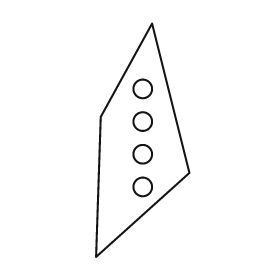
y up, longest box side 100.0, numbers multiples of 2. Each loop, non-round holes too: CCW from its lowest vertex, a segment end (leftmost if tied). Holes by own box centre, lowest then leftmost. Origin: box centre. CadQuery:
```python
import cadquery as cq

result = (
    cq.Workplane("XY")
    .moveTo(-20.0, -50.0)
    .lineTo(20.0, -14.0)
    .lineTo(4.0, 50.0)
    .lineTo(-18.0, 10.0)
    .close()
    .moveTo(0.0, -20.0)
    .circle(4.0)
    .moveTo(0.0, -6.0)
    .circle(4.0)
    .moveTo(0.0, 8.0)
    .circle(4.0)
    .moveTo(0.0, 22.0)
    .circle(4.0)
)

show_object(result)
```